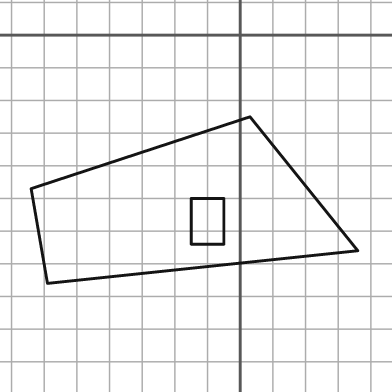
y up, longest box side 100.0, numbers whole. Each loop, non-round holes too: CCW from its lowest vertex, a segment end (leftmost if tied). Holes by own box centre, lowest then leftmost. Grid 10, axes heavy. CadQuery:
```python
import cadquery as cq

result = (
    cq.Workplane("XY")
    .moveTo(-59.0, -76.0)
    .lineTo(36.0, -66.0)
    .lineTo(3.0, -25.0)
    .lineTo(-64.0, -47.0)
    .close()
    .moveTo(-15.0, -64.0)
    .lineTo(-5.0, -64.0)
    .lineTo(-5.0, -50.0)
    .lineTo(-15.0, -50.0)
    .close()
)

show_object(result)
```